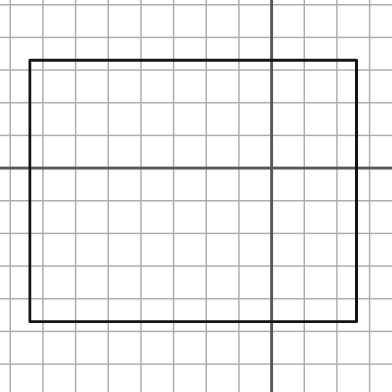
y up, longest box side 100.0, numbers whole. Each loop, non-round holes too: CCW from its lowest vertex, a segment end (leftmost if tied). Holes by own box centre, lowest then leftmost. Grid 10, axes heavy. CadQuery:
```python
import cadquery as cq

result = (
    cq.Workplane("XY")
    .moveTo(-74.0, -47.0)
    .lineTo(26.0, -47.0)
    .lineTo(26.0, 33.0)
    .lineTo(-74.0, 33.0)
    .close()
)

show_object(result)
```